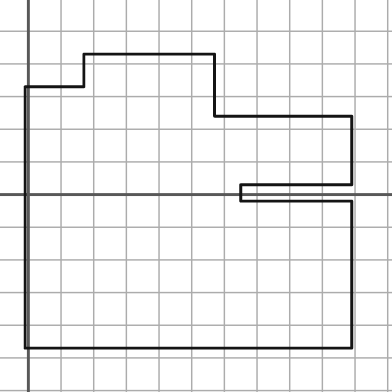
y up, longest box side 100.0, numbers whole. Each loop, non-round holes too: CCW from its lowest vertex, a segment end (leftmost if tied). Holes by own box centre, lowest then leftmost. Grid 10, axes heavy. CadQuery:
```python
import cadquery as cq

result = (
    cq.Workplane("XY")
    .moveTo(-1.0, -47.0)
    .lineTo(99.0, -47.0)
    .lineTo(99.0, -2.0)
    .lineTo(65.0, -2.0)
    .lineTo(65.0, 3.0)
    .lineTo(99.0, 3.0)
    .lineTo(99.0, 24.0)
    .lineTo(57.0, 24.0)
    .lineTo(57.0, 43.0)
    .lineTo(17.0, 43.0)
    .lineTo(17.0, 33.0)
    .lineTo(-1.0, 33.0)
    .close()
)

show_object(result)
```